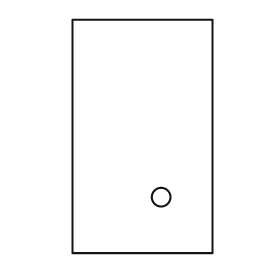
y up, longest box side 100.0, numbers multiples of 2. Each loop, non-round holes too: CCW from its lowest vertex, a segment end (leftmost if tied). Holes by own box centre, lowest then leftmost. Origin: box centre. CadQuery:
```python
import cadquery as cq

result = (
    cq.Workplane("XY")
    .moveTo(-30.0, -50.0)
    .lineTo(30.0, -50.0)
    .lineTo(30.0, 50.0)
    .lineTo(-30.0, 50.0)
    .close()
    .moveTo(8.0, -26.0)
    .circle(4.0)
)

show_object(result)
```